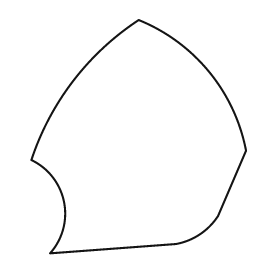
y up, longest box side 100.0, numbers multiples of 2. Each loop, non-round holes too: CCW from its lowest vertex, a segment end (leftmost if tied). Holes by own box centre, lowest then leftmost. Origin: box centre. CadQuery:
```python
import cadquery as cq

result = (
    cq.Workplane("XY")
    .moveTo(-38.0, -50.0)
    .lineTo(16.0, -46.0)
    .threePointArc((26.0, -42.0), (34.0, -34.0))
    .lineTo(46.0, -6.0)
    .threePointArc((30.0, 28.0), (0.0, 50.0))
    .threePointArc((-28.0, 24.0), (-46.0, -10.0))
    .threePointArc((-32.0, -28.0), (-38.0, -50.0))
    .close()
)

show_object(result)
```